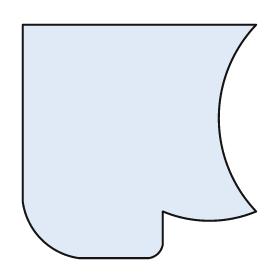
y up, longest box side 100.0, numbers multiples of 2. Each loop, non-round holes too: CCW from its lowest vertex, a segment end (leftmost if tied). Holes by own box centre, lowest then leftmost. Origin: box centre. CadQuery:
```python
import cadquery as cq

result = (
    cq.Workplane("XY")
    .moveTo(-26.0, -50.0)
    .lineTo(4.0, -50.0)
    .threePointArc((8.0, -48.0), (10.0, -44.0))
    .lineTo(10.0, -30.0)
    .threePointArc((30.0, -34.0), (50.0, -30.0))
    .threePointArc((34.0, 10.0), (50.0, 50.0))
    .lineTo(-50.0, 50.0)
    .lineTo(-50.0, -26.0)
    .threePointArc((-42.0, -42.0), (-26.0, -50.0))
    .close()
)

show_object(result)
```